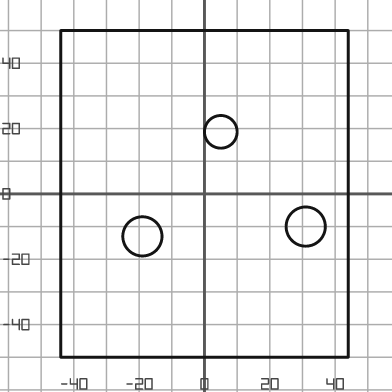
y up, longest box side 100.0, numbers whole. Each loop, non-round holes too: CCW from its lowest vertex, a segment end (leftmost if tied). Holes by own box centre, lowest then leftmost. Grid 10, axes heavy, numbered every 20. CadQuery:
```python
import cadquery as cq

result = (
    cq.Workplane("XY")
    .moveTo(-44.0, -50.0)
    .lineTo(44.0, -50.0)
    .lineTo(44.0, 50.0)
    .lineTo(-44.0, 50.0)
    .close()
    .moveTo(-19.0, -13.0)
    .circle(6.0)
    .moveTo(31.0, -10.0)
    .circle(6.0)
    .moveTo(5.0, 19.0)
    .circle(5.0)
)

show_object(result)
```